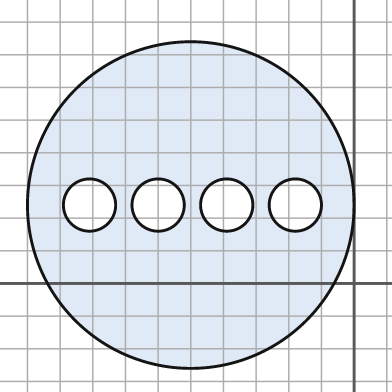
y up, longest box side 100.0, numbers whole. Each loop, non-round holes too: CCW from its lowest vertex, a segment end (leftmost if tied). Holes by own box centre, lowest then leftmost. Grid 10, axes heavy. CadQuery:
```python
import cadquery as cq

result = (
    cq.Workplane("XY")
    .moveTo(-50.0, 24.0)
    .circle(50.0)
    .moveTo(-81.0, 24.0)
    .circle(8.0)
    .moveTo(-60.0, 24.0)
    .circle(8.0)
    .moveTo(-39.0, 24.0)
    .circle(8.0)
    .moveTo(-18.0, 24.0)
    .circle(8.0)
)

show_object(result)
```